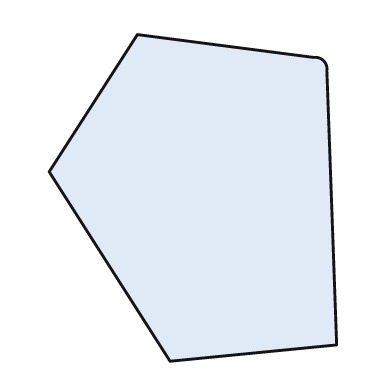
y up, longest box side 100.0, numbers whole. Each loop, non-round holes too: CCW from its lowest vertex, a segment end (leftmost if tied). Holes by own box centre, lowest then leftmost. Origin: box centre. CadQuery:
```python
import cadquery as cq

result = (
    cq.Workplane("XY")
    .moveTo(-7.0, -50.0)
    .lineTo(44.0, -45.0)
    .lineTo(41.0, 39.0)
    .threePointArc((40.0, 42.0), (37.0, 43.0))
    .lineTo(-17.0, 50.0)
    .lineTo(-44.0, 8.0)
    .close()
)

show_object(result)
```